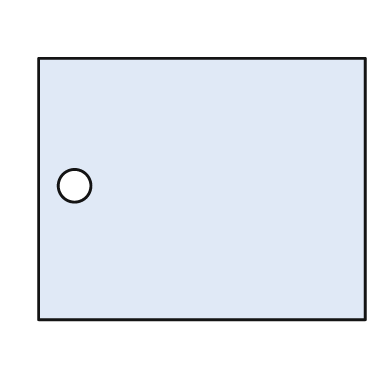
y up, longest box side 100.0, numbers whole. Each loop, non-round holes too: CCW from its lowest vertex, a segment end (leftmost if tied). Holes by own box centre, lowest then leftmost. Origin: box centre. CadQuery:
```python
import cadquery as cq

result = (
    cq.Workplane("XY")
    .moveTo(-50.0, -40.0)
    .lineTo(50.0, -40.0)
    .lineTo(50.0, 40.0)
    .lineTo(-50.0, 40.0)
    .close()
    .moveTo(-39.0, 1.0)
    .circle(5.0)
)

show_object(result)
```